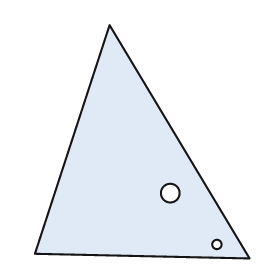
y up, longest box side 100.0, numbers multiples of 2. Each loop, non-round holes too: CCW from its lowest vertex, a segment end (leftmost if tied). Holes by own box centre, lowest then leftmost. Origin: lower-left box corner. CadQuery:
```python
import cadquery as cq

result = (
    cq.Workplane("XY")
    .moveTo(92.0, 0.0)
    .lineTo(32.0, 100.0)
    .lineTo(0.0, 2.0)
    .close()
    .moveTo(78.0, 6.0)
    .circle(2.0)
    .moveTo(58.0, 28.0)
    .circle(4.0)
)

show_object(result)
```